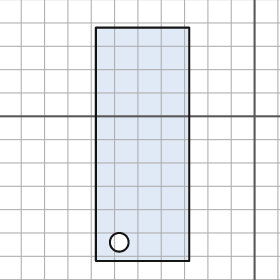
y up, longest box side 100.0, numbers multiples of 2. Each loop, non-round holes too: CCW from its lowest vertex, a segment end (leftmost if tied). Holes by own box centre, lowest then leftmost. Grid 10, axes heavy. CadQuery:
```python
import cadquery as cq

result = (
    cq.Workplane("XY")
    .moveTo(-68.0, -62.0)
    .lineTo(-28.0, -62.0)
    .lineTo(-28.0, 38.0)
    .lineTo(-68.0, 38.0)
    .close()
    .moveTo(-58.0, -54.0)
    .circle(4.0)
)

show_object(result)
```